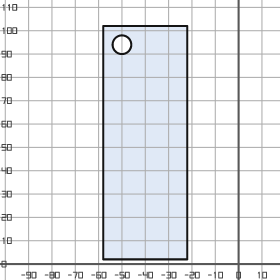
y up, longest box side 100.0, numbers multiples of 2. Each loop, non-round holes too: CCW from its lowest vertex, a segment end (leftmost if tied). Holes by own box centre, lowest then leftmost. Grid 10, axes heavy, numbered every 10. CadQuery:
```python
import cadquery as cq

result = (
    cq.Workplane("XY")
    .moveTo(-58.0, 2.0)
    .lineTo(-22.0, 2.0)
    .lineTo(-22.0, 102.0)
    .lineTo(-58.0, 102.0)
    .close()
    .moveTo(-50.0, 94.0)
    .circle(4.0)
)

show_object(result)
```